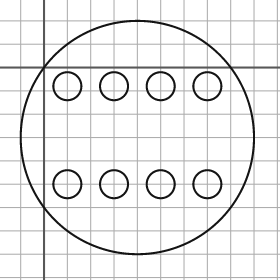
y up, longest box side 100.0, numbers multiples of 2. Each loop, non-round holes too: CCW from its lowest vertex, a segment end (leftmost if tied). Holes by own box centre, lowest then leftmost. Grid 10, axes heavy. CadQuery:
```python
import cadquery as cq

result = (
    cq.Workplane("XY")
    .moveTo(40.0, -30.0)
    .circle(50.0)
    .moveTo(10.0, -50.0)
    .circle(6.0)
    .moveTo(30.0, -50.0)
    .circle(6.0)
    .moveTo(50.0, -50.0)
    .circle(6.0)
    .moveTo(70.0, -50.0)
    .circle(6.0)
    .moveTo(10.0, -8.0)
    .circle(6.0)
    .moveTo(30.0, -8.0)
    .circle(6.0)
    .moveTo(50.0, -8.0)
    .circle(6.0)
    .moveTo(70.0, -8.0)
    .circle(6.0)
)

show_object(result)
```